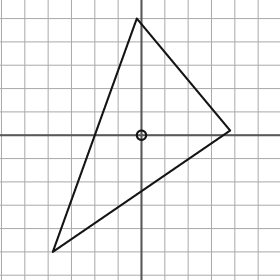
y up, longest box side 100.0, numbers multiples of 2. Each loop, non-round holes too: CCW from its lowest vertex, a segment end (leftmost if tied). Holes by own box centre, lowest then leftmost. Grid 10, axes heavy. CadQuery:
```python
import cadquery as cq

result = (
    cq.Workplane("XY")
    .moveTo(-38.0, -50.0)
    .lineTo(38.0, 2.0)
    .lineTo(-2.0, 50.0)
    .close()
    .moveTo(0.0, 0.0)
    .circle(2.0)
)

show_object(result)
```